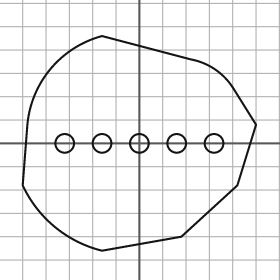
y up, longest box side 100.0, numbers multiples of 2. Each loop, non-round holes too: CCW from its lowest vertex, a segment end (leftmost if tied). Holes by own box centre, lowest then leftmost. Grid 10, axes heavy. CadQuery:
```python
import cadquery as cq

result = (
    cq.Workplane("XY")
    .moveTo(-16.0, -46.0)
    .lineTo(18.0, -40.0)
    .lineTo(42.0, -18.0)
    .lineTo(50.0, 8.0)
    .lineTo(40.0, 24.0)
    .threePointArc((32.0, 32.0), (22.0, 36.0))
    .lineTo(-16.0, 46.0)
    .threePointArc((-38.0, 32.0), (-48.0, 8.0))
    .lineTo(-50.0, -18.0)
    .threePointArc((-36.0, -36.0), (-16.0, -46.0))
    .close()
    .moveTo(-32.0, 0.0)
    .circle(4.0)
    .moveTo(-16.0, 0.0)
    .circle(4.0)
    .moveTo(0.0, 0.0)
    .circle(4.0)
    .moveTo(16.0, 0.0)
    .circle(4.0)
    .moveTo(32.0, 0.0)
    .circle(4.0)
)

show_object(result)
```